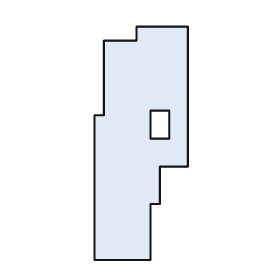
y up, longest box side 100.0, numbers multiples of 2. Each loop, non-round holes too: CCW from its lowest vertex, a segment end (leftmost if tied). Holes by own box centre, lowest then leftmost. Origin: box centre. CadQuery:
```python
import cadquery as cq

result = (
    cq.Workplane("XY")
    .moveTo(-20.0, -50.0)
    .lineTo(4.0, -50.0)
    .lineTo(4.0, -26.0)
    .lineTo(8.0, -26.0)
    .lineTo(8.0, -10.0)
    .lineTo(20.0, -10.0)
    .lineTo(20.0, 50.0)
    .lineTo(-2.0, 50.0)
    .lineTo(-2.0, 44.0)
    .lineTo(-16.0, 44.0)
    .lineTo(-16.0, 12.0)
    .lineTo(-20.0, 12.0)
    .close()
    .moveTo(4.0, 2.0)
    .lineTo(12.0, 2.0)
    .lineTo(12.0, 14.0)
    .lineTo(4.0, 14.0)
    .close()
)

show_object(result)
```